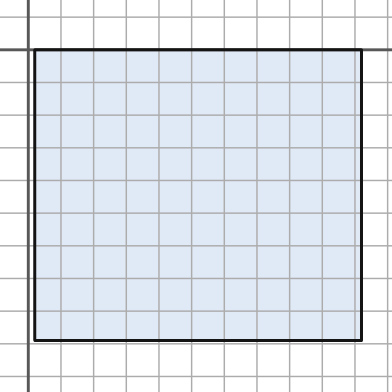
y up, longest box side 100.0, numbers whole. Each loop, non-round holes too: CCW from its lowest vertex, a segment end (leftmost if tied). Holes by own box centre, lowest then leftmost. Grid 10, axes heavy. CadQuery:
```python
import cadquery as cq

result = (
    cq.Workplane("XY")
    .moveTo(2.0, -89.0)
    .lineTo(102.0, -89.0)
    .lineTo(102.0, 0.0)
    .lineTo(2.0, 0.0)
    .close()
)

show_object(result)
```